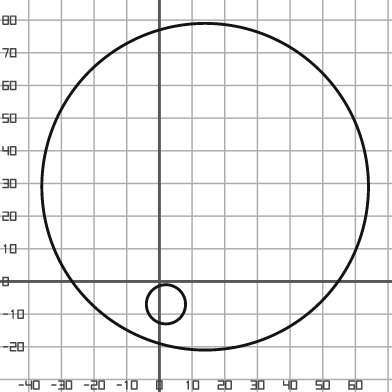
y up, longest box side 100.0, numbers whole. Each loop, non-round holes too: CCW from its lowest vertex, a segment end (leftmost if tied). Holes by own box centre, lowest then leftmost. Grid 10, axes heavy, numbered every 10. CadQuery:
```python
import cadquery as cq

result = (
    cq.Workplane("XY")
    .moveTo(14.0, 29.0)
    .circle(50.0)
    .moveTo(2.0, -7.0)
    .circle(6.0)
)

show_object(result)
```